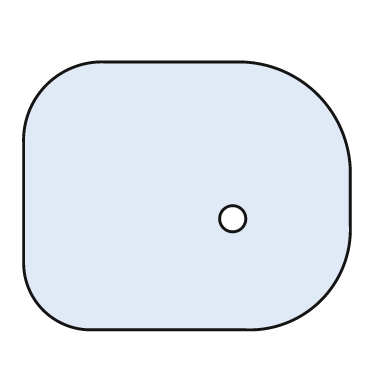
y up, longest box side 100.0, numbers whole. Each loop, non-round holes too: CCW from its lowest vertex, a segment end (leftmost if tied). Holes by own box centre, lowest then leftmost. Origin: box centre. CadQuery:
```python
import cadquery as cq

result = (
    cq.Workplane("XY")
    .moveTo(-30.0, -41.0)
    .lineTo(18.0, -41.0)
    .threePointArc((41.0, -32.0), (50.0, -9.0))
    .lineTo(50.0, 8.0)
    .threePointArc((40.0, 31.0), (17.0, 41.0))
    .lineTo(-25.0, 41.0)
    .threePointArc((-43.0, 34.0), (-50.0, 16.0))
    .lineTo(-50.0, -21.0)
    .threePointArc((-44.0, -35.0), (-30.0, -41.0))
    .close()
    .moveTo(14.0, -7.0)
    .circle(4.0)
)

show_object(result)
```